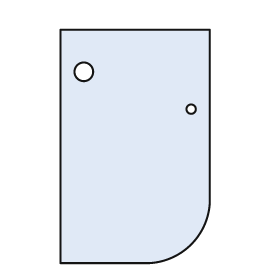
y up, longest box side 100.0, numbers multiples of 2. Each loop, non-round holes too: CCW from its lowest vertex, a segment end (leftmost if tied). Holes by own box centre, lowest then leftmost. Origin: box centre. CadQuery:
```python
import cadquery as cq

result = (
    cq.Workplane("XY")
    .moveTo(-32.0, -50.0)
    .lineTo(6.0, -50.0)
    .threePointArc((24.0, -42.0), (32.0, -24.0))
    .lineTo(32.0, 50.0)
    .lineTo(-32.0, 50.0)
    .close()
    .moveTo(24.0, 16.0)
    .circle(2.0)
    .moveTo(-22.0, 32.0)
    .circle(4.0)
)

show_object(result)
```